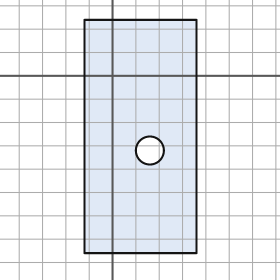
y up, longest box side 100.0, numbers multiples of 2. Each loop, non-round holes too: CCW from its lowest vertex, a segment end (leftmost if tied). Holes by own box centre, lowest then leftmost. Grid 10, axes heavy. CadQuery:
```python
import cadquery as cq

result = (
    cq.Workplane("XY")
    .moveTo(-12.0, -76.0)
    .lineTo(36.0, -76.0)
    .lineTo(36.0, 24.0)
    .lineTo(-12.0, 24.0)
    .close()
    .moveTo(16.0, -32.0)
    .circle(6.0)
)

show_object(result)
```